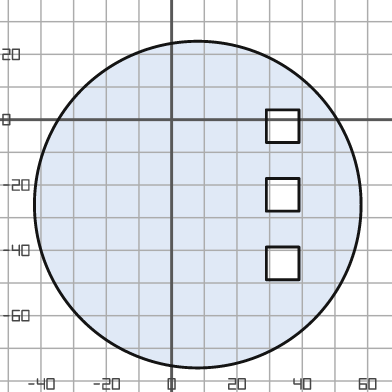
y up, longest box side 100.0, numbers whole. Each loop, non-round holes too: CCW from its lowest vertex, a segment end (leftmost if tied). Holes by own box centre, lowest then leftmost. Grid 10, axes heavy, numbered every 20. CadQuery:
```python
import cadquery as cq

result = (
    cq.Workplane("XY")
    .moveTo(8.0, -26.0)
    .circle(50.0)
    .moveTo(29.0, -49.0)
    .lineTo(39.0, -49.0)
    .lineTo(39.0, -39.0)
    .lineTo(29.0, -39.0)
    .close()
    .moveTo(29.0, -28.0)
    .lineTo(39.0, -28.0)
    .lineTo(39.0, -18.0)
    .lineTo(29.0, -18.0)
    .close()
    .moveTo(29.0, -7.0)
    .lineTo(39.0, -7.0)
    .lineTo(39.0, 3.0)
    .lineTo(29.0, 3.0)
    .close()
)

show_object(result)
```